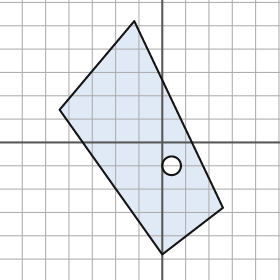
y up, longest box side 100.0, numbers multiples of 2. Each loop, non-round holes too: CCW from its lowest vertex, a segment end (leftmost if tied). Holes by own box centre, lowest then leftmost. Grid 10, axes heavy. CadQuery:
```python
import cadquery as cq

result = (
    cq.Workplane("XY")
    .moveTo(0.0, -48.0)
    .lineTo(26.0, -28.0)
    .lineTo(-12.0, 52.0)
    .lineTo(-44.0, 14.0)
    .close()
    .moveTo(4.0, -10.0)
    .circle(4.0)
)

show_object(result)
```